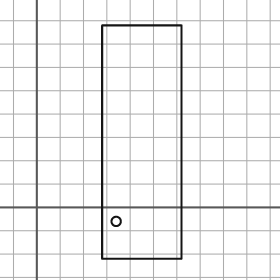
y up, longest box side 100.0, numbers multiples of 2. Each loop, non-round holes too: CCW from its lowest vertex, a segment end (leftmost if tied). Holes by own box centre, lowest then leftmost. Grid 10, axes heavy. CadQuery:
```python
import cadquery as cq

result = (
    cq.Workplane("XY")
    .moveTo(28.0, -22.0)
    .lineTo(62.0, -22.0)
    .lineTo(62.0, 78.0)
    .lineTo(28.0, 78.0)
    .close()
    .moveTo(34.0, -6.0)
    .circle(2.0)
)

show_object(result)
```